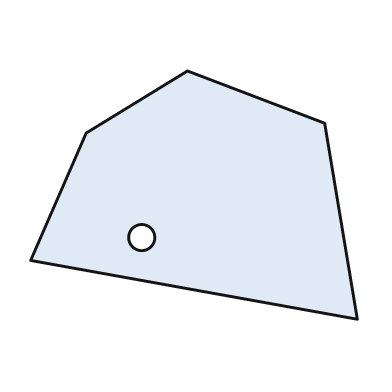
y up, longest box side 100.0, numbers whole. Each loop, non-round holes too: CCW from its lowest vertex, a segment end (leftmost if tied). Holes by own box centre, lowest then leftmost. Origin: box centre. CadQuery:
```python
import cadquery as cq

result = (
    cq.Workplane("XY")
    .moveTo(50.0, -38.0)
    .lineTo(40.0, 22.0)
    .lineTo(-2.0, 38.0)
    .lineTo(-33.0, 19.0)
    .lineTo(-50.0, -20.0)
    .close()
    .moveTo(-16.0, -13.0)
    .circle(4.0)
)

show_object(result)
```